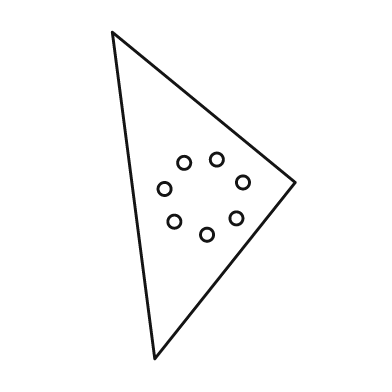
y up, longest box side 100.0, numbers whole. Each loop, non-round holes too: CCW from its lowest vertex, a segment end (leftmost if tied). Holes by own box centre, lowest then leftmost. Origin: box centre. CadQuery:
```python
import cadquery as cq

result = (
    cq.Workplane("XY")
    .moveTo(-15.0, -50.0)
    .lineTo(28.0, 4.0)
    .lineTo(-28.0, 50.0)
    .close()
    .moveTo(1.0, -12.0)
    .circle(2.0)
    .moveTo(-9.0, -8.0)
    .circle(2.0)
    .moveTo(10.0, -7.0)
    .circle(2.0)
    .moveTo(-12.0, 2.0)
    .circle(2.0)
    .moveTo(12.0, 4.0)
    .circle(2.0)
    .moveTo(-6.0, 10.0)
    .circle(2.0)
    .moveTo(4.0, 11.0)
    .circle(2.0)
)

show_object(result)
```